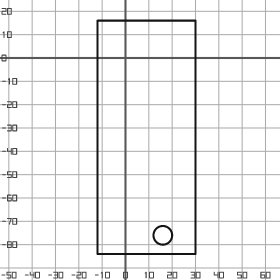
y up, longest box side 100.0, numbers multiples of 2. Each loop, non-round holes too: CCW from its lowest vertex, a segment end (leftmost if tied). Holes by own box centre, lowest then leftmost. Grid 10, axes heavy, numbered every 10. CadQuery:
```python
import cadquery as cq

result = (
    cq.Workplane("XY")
    .moveTo(-12.0, -84.0)
    .lineTo(30.0, -84.0)
    .lineTo(30.0, 16.0)
    .lineTo(-12.0, 16.0)
    .close()
    .moveTo(16.0, -76.0)
    .circle(4.0)
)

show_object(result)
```